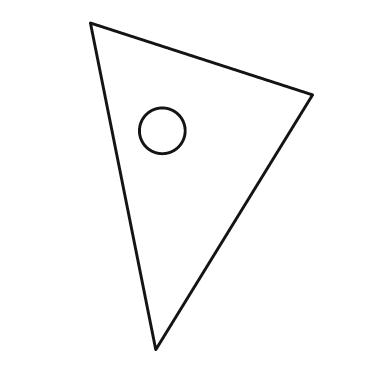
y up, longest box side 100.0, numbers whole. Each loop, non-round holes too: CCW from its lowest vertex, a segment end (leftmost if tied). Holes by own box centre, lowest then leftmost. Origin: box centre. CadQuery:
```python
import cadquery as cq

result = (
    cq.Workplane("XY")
    .moveTo(-14.0, -50.0)
    .lineTo(34.0, 28.0)
    .lineTo(-34.0, 50.0)
    .close()
    .moveTo(-12.0, 17.0)
    .circle(7.0)
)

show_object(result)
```